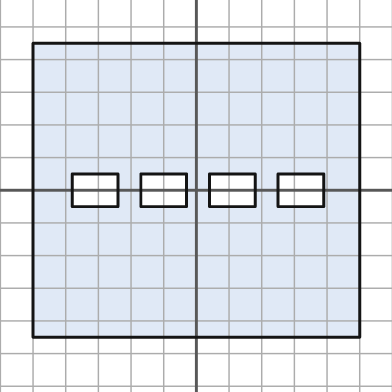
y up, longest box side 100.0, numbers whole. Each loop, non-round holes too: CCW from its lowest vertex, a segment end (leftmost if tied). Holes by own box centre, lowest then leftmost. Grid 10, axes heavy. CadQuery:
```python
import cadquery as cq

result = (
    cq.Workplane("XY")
    .moveTo(-50.0, -45.0)
    .lineTo(50.0, -45.0)
    .lineTo(50.0, 45.0)
    .lineTo(-50.0, 45.0)
    .close()
    .moveTo(-38.0, -5.0)
    .lineTo(-24.0, -5.0)
    .lineTo(-24.0, 5.0)
    .lineTo(-38.0, 5.0)
    .close()
    .moveTo(-17.0, -5.0)
    .lineTo(-3.0, -5.0)
    .lineTo(-3.0, 5.0)
    .lineTo(-17.0, 5.0)
    .close()
    .moveTo(4.0, -5.0)
    .lineTo(18.0, -5.0)
    .lineTo(18.0, 5.0)
    .lineTo(4.0, 5.0)
    .close()
    .moveTo(25.0, -5.0)
    .lineTo(39.0, -5.0)
    .lineTo(39.0, 5.0)
    .lineTo(25.0, 5.0)
    .close()
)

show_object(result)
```